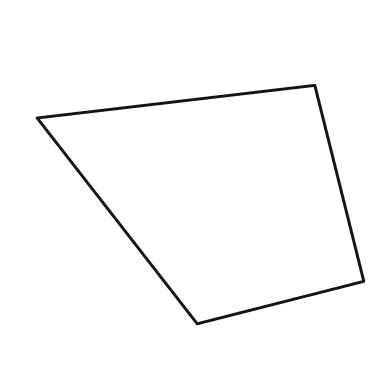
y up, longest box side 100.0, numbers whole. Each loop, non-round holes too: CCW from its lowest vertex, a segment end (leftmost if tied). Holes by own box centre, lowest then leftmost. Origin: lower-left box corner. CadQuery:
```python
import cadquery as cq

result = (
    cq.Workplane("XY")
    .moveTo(49.0, 0.0)
    .lineTo(100.0, 13.0)
    .lineTo(85.0, 73.0)
    .lineTo(0.0, 63.0)
    .close()
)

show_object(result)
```